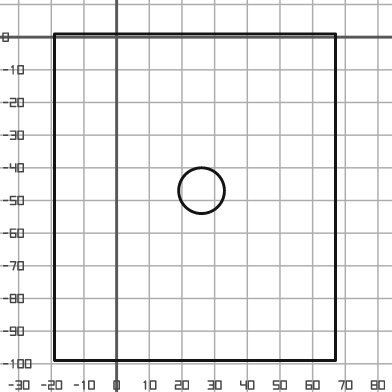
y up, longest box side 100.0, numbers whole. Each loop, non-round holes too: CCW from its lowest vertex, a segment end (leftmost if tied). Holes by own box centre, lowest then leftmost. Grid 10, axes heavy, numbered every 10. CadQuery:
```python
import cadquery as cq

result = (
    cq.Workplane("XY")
    .moveTo(-19.0, -99.0)
    .lineTo(67.0, -99.0)
    .lineTo(67.0, 1.0)
    .lineTo(-19.0, 1.0)
    .close()
    .moveTo(26.0, -47.0)
    .circle(7.0)
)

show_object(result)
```